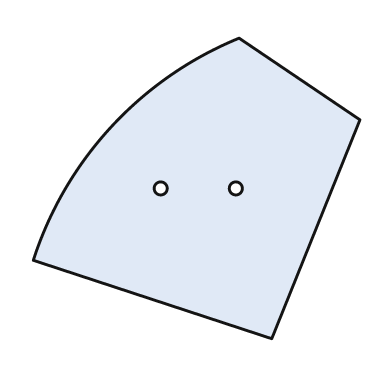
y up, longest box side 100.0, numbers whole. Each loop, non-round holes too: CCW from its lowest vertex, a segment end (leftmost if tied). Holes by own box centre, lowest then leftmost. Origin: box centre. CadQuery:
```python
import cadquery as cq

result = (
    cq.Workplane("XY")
    .moveTo(23.0, -46.0)
    .lineTo(50.0, 21.0)
    .lineTo(13.0, 46.0)
    .threePointArc((-26.0, 19.0), (-50.0, -22.0))
    .close()
    .moveTo(-11.0, 0.0)
    .circle(2.0)
    .moveTo(12.0, 0.0)
    .circle(2.0)
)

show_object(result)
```